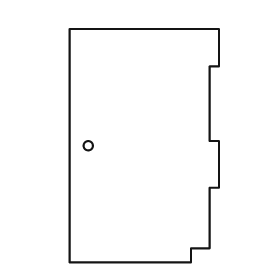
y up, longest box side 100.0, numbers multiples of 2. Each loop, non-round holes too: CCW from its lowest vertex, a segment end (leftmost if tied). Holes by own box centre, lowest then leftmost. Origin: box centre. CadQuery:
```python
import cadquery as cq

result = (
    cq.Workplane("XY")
    .moveTo(-32.0, -50.0)
    .lineTo(20.0, -50.0)
    .lineTo(20.0, -44.0)
    .lineTo(28.0, -44.0)
    .lineTo(28.0, -18.0)
    .lineTo(32.0, -18.0)
    .lineTo(32.0, 2.0)
    .lineTo(28.0, 2.0)
    .lineTo(28.0, 34.0)
    .lineTo(32.0, 34.0)
    .lineTo(32.0, 50.0)
    .lineTo(-32.0, 50.0)
    .close()
    .moveTo(-24.0, 0.0)
    .circle(2.0)
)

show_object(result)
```